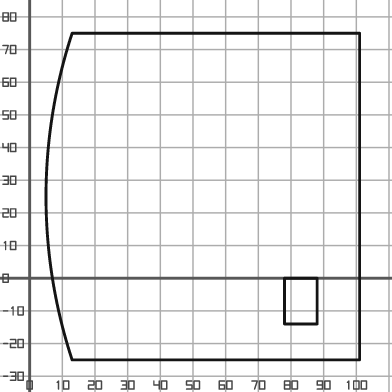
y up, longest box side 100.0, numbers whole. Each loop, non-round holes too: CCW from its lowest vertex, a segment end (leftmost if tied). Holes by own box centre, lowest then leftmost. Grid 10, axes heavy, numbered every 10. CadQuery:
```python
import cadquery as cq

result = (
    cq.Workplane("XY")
    .moveTo(13.0, -25.0)
    .lineTo(101.0, -25.0)
    .lineTo(101.0, 75.0)
    .lineTo(13.0, 75.0)
    .threePointArc((5.0, 25.0), (13.0, -25.0))
    .close()
    .moveTo(78.0, -14.0)
    .lineTo(88.0, -14.0)
    .lineTo(88.0, 0.0)
    .lineTo(78.0, 0.0)
    .close()
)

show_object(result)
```